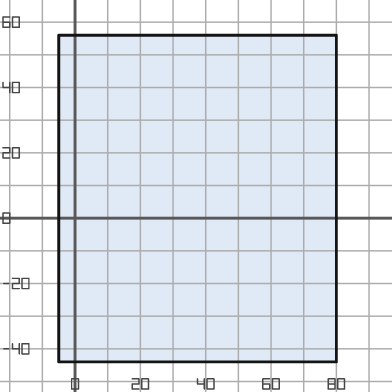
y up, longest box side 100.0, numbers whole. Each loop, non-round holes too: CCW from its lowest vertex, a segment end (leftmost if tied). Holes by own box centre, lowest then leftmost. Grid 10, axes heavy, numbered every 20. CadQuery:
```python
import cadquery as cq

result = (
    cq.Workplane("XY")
    .moveTo(-5.0, -44.0)
    .lineTo(80.0, -44.0)
    .lineTo(80.0, 56.0)
    .lineTo(-5.0, 56.0)
    .close()
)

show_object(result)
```